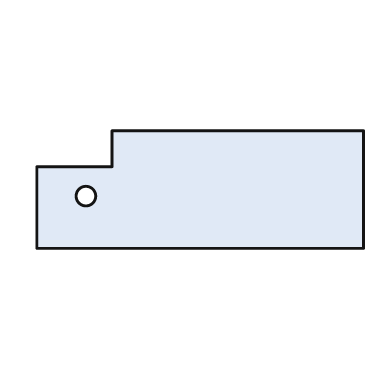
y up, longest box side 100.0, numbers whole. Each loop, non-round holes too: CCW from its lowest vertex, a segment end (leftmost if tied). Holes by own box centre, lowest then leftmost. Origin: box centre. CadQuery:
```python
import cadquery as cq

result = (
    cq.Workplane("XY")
    .moveTo(-50.0, -18.0)
    .lineTo(50.0, -18.0)
    .lineTo(50.0, 18.0)
    .lineTo(-27.0, 18.0)
    .lineTo(-27.0, 7.0)
    .lineTo(-50.0, 7.0)
    .close()
    .moveTo(-35.0, -2.0)
    .circle(3.0)
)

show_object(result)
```